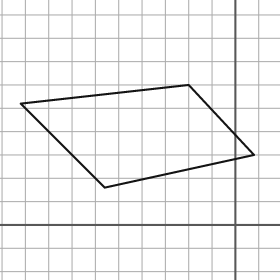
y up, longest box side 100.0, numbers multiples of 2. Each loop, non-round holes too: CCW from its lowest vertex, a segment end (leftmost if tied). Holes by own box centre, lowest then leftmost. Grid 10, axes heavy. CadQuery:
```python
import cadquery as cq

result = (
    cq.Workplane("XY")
    .moveTo(-56.0, 16.0)
    .lineTo(8.0, 30.0)
    .lineTo(-20.0, 60.0)
    .lineTo(-92.0, 52.0)
    .close()
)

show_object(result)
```